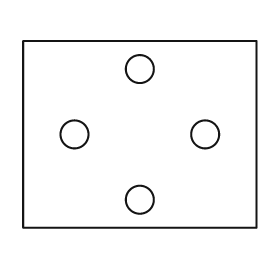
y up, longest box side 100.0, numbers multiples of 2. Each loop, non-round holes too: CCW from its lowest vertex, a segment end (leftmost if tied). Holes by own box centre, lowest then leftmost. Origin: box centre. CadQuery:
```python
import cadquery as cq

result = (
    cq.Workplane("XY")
    .moveTo(-50.0, -40.0)
    .lineTo(50.0, -40.0)
    .lineTo(50.0, 40.0)
    .lineTo(-50.0, 40.0)
    .close()
    .moveTo(0.0, -28.0)
    .circle(6.0)
    .moveTo(-28.0, 0.0)
    .circle(6.0)
    .moveTo(28.0, 0.0)
    .circle(6.0)
    .moveTo(0.0, 28.0)
    .circle(6.0)
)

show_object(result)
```